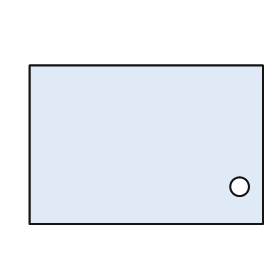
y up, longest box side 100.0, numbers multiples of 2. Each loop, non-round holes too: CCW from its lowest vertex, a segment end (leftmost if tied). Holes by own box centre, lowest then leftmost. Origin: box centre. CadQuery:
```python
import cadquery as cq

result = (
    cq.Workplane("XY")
    .moveTo(-50.0, -34.0)
    .lineTo(50.0, -34.0)
    .lineTo(50.0, 34.0)
    .lineTo(-50.0, 34.0)
    .close()
    .moveTo(40.0, -18.0)
    .circle(4.0)
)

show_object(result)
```